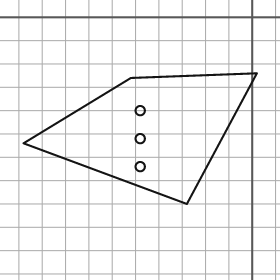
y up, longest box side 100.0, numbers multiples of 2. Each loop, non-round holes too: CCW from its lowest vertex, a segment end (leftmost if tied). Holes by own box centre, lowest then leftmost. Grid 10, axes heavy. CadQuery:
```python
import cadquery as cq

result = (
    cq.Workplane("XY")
    .moveTo(-28.0, -80.0)
    .lineTo(2.0, -24.0)
    .lineTo(-52.0, -26.0)
    .lineTo(-98.0, -54.0)
    .close()
    .moveTo(-48.0, -64.0)
    .circle(2.0)
    .moveTo(-48.0, -52.0)
    .circle(2.0)
    .moveTo(-48.0, -40.0)
    .circle(2.0)
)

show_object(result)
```